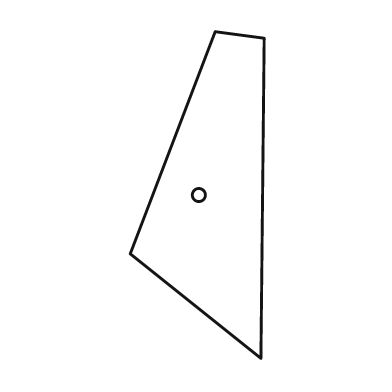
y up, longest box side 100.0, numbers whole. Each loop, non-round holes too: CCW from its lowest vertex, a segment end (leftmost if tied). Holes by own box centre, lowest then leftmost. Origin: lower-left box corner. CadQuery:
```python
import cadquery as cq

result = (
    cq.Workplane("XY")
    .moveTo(40.0, 0.0)
    .lineTo(41.0, 98.0)
    .lineTo(26.0, 100.0)
    .lineTo(0.0, 32.0)
    .close()
    .moveTo(21.0, 50.0)
    .circle(2.0)
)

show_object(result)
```